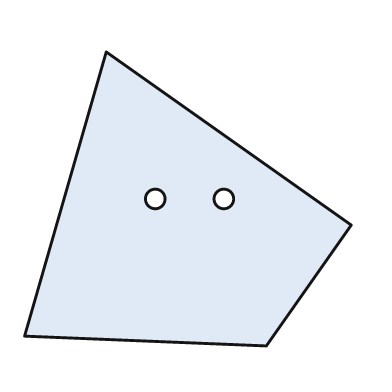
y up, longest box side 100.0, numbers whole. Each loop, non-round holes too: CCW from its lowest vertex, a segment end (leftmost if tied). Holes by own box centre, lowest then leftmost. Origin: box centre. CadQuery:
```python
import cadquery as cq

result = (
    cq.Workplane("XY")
    .moveTo(24.0, -45.0)
    .lineTo(50.0, -8.0)
    .lineTo(-25.0, 45.0)
    .lineTo(-50.0, -42.0)
    .close()
    .moveTo(-10.0, 0.0)
    .circle(3.0)
    .moveTo(11.0, 0.0)
    .circle(3.0)
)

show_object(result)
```